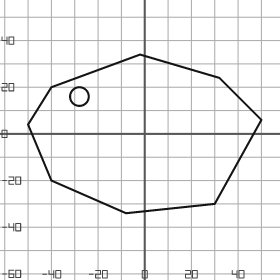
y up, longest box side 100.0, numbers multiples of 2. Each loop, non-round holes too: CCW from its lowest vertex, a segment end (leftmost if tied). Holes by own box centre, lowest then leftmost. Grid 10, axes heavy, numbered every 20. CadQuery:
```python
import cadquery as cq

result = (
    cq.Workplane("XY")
    .moveTo(-8.0, -34.0)
    .lineTo(30.0, -30.0)
    .lineTo(50.0, 6.0)
    .lineTo(32.0, 24.0)
    .lineTo(-2.0, 34.0)
    .lineTo(-40.0, 20.0)
    .lineTo(-50.0, 4.0)
    .lineTo(-40.0, -20.0)
    .close()
    .moveTo(-28.0, 16.0)
    .circle(4.0)
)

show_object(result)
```